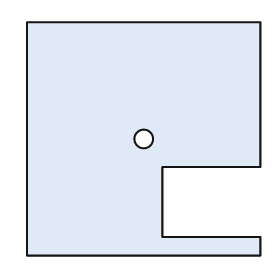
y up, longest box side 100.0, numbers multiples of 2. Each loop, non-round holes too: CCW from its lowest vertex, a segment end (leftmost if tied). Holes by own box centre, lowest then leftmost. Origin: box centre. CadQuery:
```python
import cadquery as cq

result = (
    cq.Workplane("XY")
    .moveTo(-50.0, -50.0)
    .lineTo(50.0, -50.0)
    .lineTo(50.0, -42.0)
    .lineTo(8.0, -42.0)
    .lineTo(8.0, -12.0)
    .lineTo(50.0, -12.0)
    .lineTo(50.0, 50.0)
    .lineTo(-50.0, 50.0)
    .close()
    .moveTo(0.0, 0.0)
    .circle(4.0)
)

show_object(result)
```